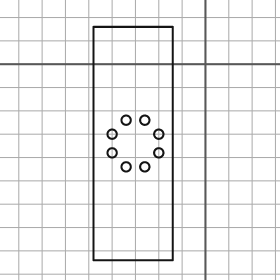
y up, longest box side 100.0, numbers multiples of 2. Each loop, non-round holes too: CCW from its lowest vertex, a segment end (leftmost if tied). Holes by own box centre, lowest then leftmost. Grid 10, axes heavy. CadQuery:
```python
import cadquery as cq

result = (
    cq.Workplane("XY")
    .moveTo(-48.0, -84.0)
    .lineTo(-14.0, -84.0)
    .lineTo(-14.0, 16.0)
    .lineTo(-48.0, 16.0)
    .close()
    .moveTo(-34.0, -44.0)
    .circle(2.0)
    .moveTo(-26.0, -44.0)
    .circle(2.0)
    .moveTo(-40.0, -38.0)
    .circle(2.0)
    .moveTo(-20.0, -38.0)
    .circle(2.0)
    .moveTo(-40.0, -30.0)
    .circle(2.0)
    .moveTo(-20.0, -30.0)
    .circle(2.0)
    .moveTo(-34.0, -24.0)
    .circle(2.0)
    .moveTo(-26.0, -24.0)
    .circle(2.0)
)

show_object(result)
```